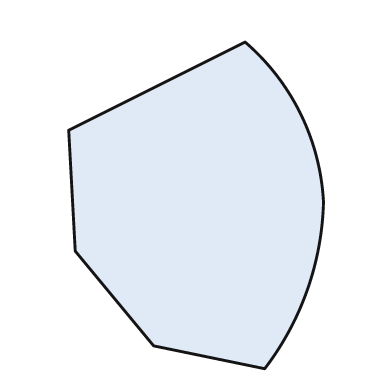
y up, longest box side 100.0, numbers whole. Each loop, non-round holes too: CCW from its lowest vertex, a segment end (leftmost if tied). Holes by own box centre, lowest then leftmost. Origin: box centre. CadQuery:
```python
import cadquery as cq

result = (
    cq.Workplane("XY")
    .moveTo(21.0, -50.0)
    .threePointArc((34.0, -26.0), (39.0, 1.0))
    .threePointArc((32.0, 28.0), (15.0, 50.0))
    .lineTo(-39.0, 23.0)
    .lineTo(-37.0, -14.0)
    .lineTo(-13.0, -43.0)
    .close()
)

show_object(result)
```